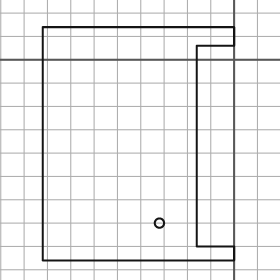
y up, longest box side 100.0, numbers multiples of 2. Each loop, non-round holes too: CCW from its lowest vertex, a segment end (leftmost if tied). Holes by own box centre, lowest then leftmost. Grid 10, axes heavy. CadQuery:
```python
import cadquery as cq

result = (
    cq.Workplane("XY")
    .moveTo(-82.0, -86.0)
    .lineTo(0.0, -86.0)
    .lineTo(0.0, -80.0)
    .lineTo(-16.0, -80.0)
    .lineTo(-16.0, 6.0)
    .lineTo(0.0, 6.0)
    .lineTo(0.0, 14.0)
    .lineTo(-82.0, 14.0)
    .close()
    .moveTo(-32.0, -70.0)
    .circle(2.0)
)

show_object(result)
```